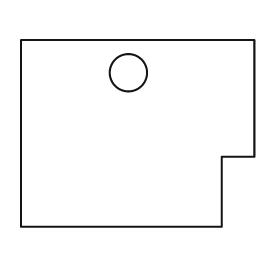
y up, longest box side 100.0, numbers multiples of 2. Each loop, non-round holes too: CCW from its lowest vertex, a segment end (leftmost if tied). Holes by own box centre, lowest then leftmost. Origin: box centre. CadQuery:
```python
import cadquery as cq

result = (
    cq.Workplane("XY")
    .moveTo(-50.0, -40.0)
    .lineTo(36.0, -40.0)
    .lineTo(36.0, -10.0)
    .lineTo(50.0, -10.0)
    .lineTo(50.0, 40.0)
    .lineTo(-50.0, 40.0)
    .close()
    .moveTo(-4.0, 26.0)
    .circle(8.0)
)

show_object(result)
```